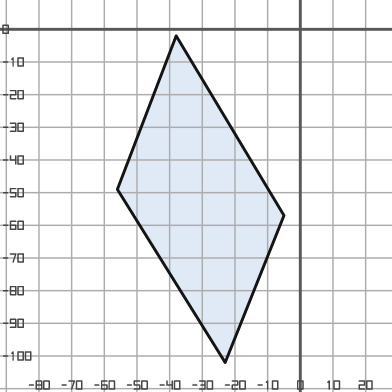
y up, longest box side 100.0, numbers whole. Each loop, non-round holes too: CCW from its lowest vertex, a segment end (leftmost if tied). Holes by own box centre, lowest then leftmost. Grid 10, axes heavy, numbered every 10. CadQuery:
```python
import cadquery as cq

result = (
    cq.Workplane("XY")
    .moveTo(-23.0, -102.0)
    .lineTo(-5.0, -57.0)
    .lineTo(-38.0, -2.0)
    .lineTo(-56.0, -49.0)
    .close()
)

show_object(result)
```